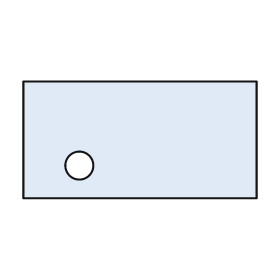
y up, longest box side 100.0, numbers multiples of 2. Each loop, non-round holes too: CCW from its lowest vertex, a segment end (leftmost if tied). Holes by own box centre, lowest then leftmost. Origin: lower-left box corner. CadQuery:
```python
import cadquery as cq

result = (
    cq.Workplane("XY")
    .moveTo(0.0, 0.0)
    .lineTo(100.0, 0.0)
    .lineTo(100.0, 50.0)
    .lineTo(0.0, 50.0)
    .close()
    .moveTo(24.0, 14.0)
    .circle(6.0)
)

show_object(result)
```